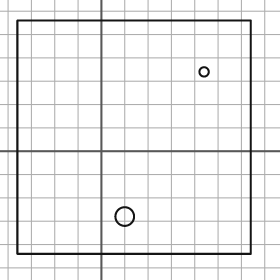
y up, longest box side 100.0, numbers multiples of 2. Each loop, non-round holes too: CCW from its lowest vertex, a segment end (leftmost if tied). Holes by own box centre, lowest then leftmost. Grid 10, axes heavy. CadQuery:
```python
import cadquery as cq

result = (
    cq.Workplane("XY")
    .moveTo(-36.0, -44.0)
    .lineTo(64.0, -44.0)
    .lineTo(64.0, 56.0)
    .lineTo(-36.0, 56.0)
    .close()
    .moveTo(10.0, -28.0)
    .circle(4.0)
    .moveTo(44.0, 34.0)
    .circle(2.0)
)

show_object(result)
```